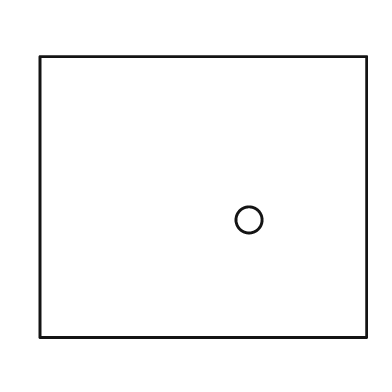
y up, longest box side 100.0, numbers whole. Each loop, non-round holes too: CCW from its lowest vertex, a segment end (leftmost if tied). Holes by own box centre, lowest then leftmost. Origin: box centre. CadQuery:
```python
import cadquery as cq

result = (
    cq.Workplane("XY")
    .moveTo(-50.0, -43.0)
    .lineTo(50.0, -43.0)
    .lineTo(50.0, 43.0)
    .lineTo(-50.0, 43.0)
    .close()
    .moveTo(14.0, -7.0)
    .circle(4.0)
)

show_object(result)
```